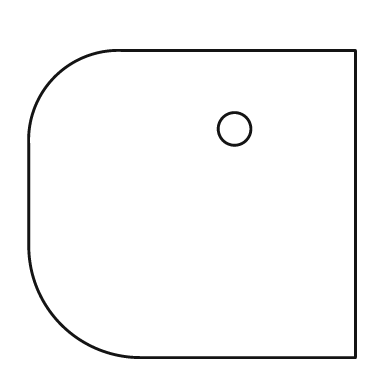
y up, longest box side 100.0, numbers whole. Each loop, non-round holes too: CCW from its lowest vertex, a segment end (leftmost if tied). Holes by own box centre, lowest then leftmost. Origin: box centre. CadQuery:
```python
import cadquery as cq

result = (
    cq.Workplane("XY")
    .moveTo(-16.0, -47.0)
    .lineTo(50.0, -47.0)
    .lineTo(50.0, 47.0)
    .lineTo(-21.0, 47.0)
    .threePointArc((-42.0, 39.0), (-50.0, 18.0))
    .lineTo(-50.0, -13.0)
    .threePointArc((-40.0, -37.0), (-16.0, -47.0))
    .close()
    .moveTo(13.0, 23.0)
    .circle(5.0)
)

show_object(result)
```